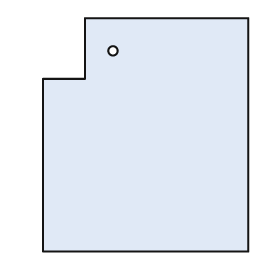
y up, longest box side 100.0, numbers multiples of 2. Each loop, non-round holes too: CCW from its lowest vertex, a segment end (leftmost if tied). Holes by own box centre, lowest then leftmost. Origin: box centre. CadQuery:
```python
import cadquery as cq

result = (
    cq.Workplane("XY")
    .moveTo(-44.0, -50.0)
    .lineTo(44.0, -50.0)
    .lineTo(44.0, 50.0)
    .lineTo(-26.0, 50.0)
    .lineTo(-26.0, 24.0)
    .lineTo(-44.0, 24.0)
    .close()
    .moveTo(-14.0, 36.0)
    .circle(2.0)
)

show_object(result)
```